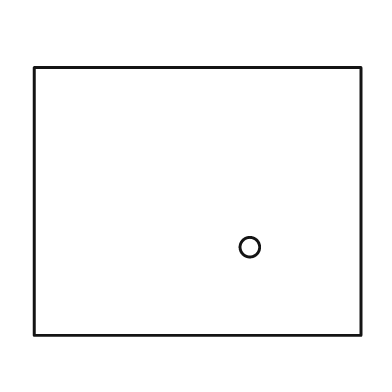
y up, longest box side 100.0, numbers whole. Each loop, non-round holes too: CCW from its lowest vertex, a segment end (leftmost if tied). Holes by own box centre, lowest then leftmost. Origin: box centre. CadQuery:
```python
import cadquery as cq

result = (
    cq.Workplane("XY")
    .moveTo(-50.0, -41.0)
    .lineTo(50.0, -41.0)
    .lineTo(50.0, 41.0)
    .lineTo(-50.0, 41.0)
    .close()
    .moveTo(16.0, -14.0)
    .circle(3.0)
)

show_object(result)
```